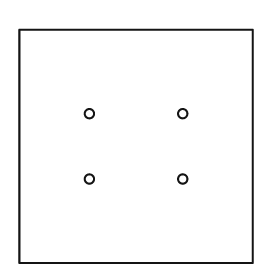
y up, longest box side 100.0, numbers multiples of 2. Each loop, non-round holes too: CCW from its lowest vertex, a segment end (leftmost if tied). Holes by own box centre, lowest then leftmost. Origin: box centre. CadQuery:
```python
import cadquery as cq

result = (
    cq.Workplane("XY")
    .moveTo(-50.0, -50.0)
    .lineTo(50.0, -50.0)
    .lineTo(50.0, 50.0)
    .lineTo(-50.0, 50.0)
    .close()
    .moveTo(-20.0, -14.0)
    .circle(2.0)
    .moveTo(20.0, -14.0)
    .circle(2.0)
    .moveTo(-20.0, 14.0)
    .circle(2.0)
    .moveTo(20.0, 14.0)
    .circle(2.0)
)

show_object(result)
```